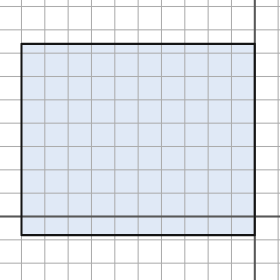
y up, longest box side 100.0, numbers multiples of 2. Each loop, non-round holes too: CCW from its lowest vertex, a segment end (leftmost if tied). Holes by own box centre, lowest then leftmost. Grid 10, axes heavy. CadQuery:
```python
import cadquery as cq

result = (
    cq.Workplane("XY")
    .moveTo(-100.0, -8.0)
    .lineTo(0.0, -8.0)
    .lineTo(0.0, 74.0)
    .lineTo(-100.0, 74.0)
    .close()
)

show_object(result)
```